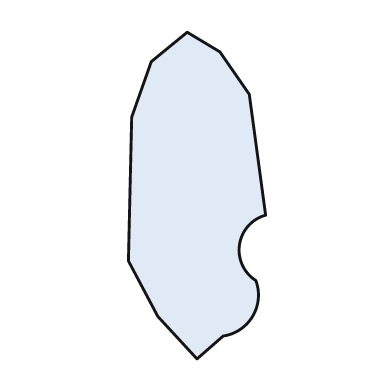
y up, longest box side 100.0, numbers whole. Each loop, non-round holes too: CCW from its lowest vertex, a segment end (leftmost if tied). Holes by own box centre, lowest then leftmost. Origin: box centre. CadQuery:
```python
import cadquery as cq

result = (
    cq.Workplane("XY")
    .moveTo(0.0, -50.0)
    .lineTo(8.0, -43.0)
    .threePointArc((17.0, -37.0), (18.0, -26.0))
    .threePointArc((13.0, -15.0), (21.0, -6.0))
    .lineTo(16.0, 31.0)
    .lineTo(7.0, 44.0)
    .lineTo(-3.0, 50.0)
    .lineTo(-14.0, 41.0)
    .lineTo(-20.0, 24.0)
    .lineTo(-21.0, -20.0)
    .lineTo(-12.0, -37.0)
    .close()
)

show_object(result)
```